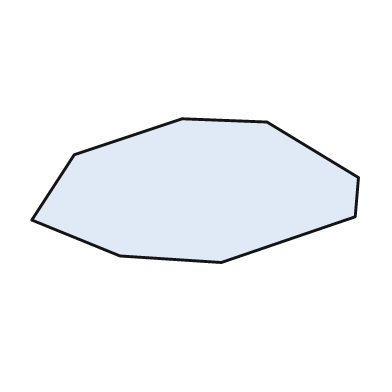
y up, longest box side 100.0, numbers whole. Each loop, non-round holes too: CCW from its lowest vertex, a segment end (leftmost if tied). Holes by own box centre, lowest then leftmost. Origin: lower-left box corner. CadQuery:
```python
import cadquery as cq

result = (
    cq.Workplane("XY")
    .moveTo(58.0, 0.0)
    .lineTo(99.0, 14.0)
    .lineTo(100.0, 26.0)
    .lineTo(72.0, 43.0)
    .lineTo(46.0, 44.0)
    .lineTo(13.0, 33.0)
    .lineTo(0.0, 13.0)
    .lineTo(27.0, 2.0)
    .close()
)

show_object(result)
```